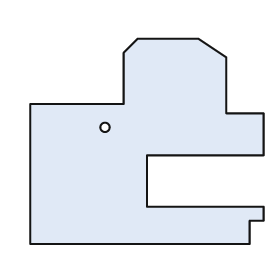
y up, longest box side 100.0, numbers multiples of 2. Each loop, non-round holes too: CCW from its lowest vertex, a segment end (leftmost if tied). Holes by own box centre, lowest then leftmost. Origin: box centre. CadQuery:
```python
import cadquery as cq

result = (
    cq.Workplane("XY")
    .moveTo(-50.0, -44.0)
    .lineTo(44.0, -44.0)
    .lineTo(44.0, -34.0)
    .lineTo(50.0, -34.0)
    .lineTo(50.0, -28.0)
    .lineTo(0.0, -28.0)
    .lineTo(0.0, -6.0)
    .lineTo(50.0, -6.0)
    .lineTo(50.0, 12.0)
    .lineTo(34.0, 12.0)
    .lineTo(34.0, 36.0)
    .lineTo(22.0, 44.0)
    .lineTo(-4.0, 44.0)
    .lineTo(-10.0, 38.0)
    .lineTo(-10.0, 16.0)
    .lineTo(-50.0, 16.0)
    .close()
    .moveTo(-18.0, 6.0)
    .circle(2.0)
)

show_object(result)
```